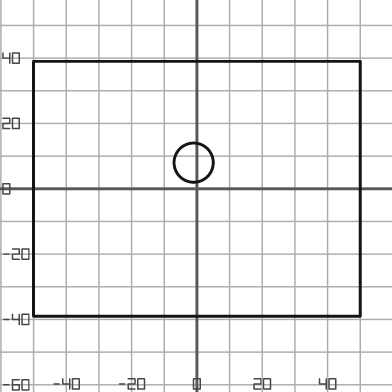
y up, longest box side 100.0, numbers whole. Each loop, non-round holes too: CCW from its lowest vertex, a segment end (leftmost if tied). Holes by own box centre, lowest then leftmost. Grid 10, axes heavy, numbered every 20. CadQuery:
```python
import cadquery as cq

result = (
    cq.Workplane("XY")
    .moveTo(-50.0, -39.0)
    .lineTo(50.0, -39.0)
    .lineTo(50.0, 39.0)
    .lineTo(-50.0, 39.0)
    .close()
    .moveTo(-1.0, 8.0)
    .circle(6.0)
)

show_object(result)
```